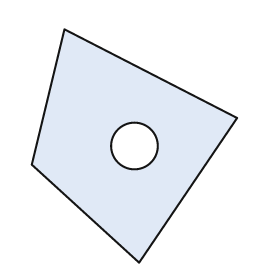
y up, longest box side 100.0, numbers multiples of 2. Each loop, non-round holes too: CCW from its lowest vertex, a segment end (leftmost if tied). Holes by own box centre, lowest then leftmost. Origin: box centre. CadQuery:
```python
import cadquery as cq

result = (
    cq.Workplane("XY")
    .moveTo(2.0, -50.0)
    .lineTo(44.0, 12.0)
    .lineTo(-30.0, 50.0)
    .lineTo(-44.0, -8.0)
    .close()
    .moveTo(0.0, 0.0)
    .circle(10.0)
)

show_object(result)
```